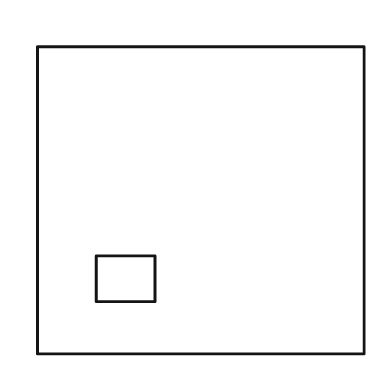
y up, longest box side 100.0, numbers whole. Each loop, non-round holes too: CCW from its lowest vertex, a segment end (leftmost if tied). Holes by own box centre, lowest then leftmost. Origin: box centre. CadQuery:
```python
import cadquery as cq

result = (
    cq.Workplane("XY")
    .moveTo(-50.0, -47.0)
    .lineTo(50.0, -47.0)
    .lineTo(50.0, 47.0)
    .lineTo(-50.0, 47.0)
    .close()
    .moveTo(-32.0, -31.0)
    .lineTo(-14.0, -31.0)
    .lineTo(-14.0, -17.0)
    .lineTo(-32.0, -17.0)
    .close()
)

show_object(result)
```